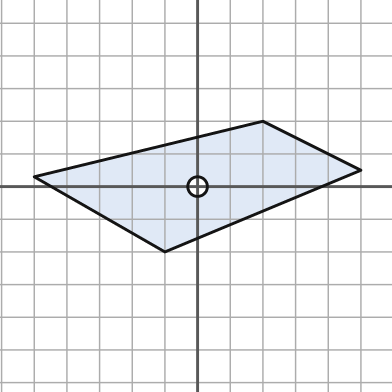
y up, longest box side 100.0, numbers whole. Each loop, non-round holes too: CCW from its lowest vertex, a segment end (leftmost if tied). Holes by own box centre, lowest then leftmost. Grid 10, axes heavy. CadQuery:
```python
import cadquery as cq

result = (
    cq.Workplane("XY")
    .moveTo(-10.0, -20.0)
    .lineTo(50.0, 5.0)
    .lineTo(20.0, 20.0)
    .lineTo(-50.0, 3.0)
    .close()
    .moveTo(0.0, 0.0)
    .circle(3.0)
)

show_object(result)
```